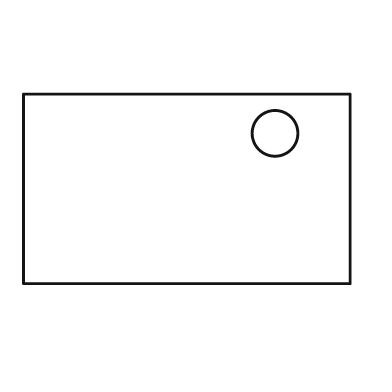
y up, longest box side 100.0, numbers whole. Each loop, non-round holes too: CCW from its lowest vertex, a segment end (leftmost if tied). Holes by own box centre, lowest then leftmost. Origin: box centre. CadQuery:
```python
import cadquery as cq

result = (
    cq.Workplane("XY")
    .moveTo(-50.0, -29.0)
    .lineTo(50.0, -29.0)
    .lineTo(50.0, 29.0)
    .lineTo(-50.0, 29.0)
    .close()
    .moveTo(27.0, 17.0)
    .circle(7.0)
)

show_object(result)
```